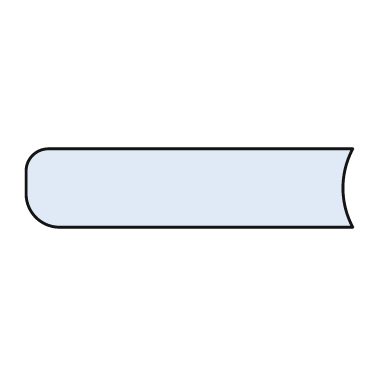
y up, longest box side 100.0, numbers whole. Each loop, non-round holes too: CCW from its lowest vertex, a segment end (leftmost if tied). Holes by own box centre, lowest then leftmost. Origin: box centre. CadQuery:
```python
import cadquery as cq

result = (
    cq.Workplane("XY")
    .moveTo(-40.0, -12.0)
    .lineTo(50.0, -12.0)
    .threePointArc((47.0, 0.0), (50.0, 12.0))
    .lineTo(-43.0, 12.0)
    .threePointArc((-48.0, 10.0), (-50.0, 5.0))
    .lineTo(-50.0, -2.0)
    .threePointArc((-47.0, -9.0), (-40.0, -12.0))
    .close()
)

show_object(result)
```